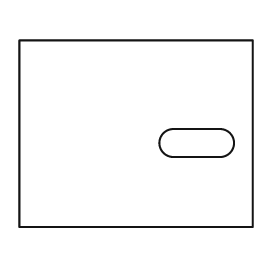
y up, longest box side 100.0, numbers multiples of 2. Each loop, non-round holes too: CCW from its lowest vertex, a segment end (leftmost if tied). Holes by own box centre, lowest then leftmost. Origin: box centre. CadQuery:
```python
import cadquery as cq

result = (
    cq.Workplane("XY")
    .moveTo(-50.0, -40.0)
    .lineTo(50.0, -40.0)
    .lineTo(50.0, 40.0)
    .lineTo(-50.0, 40.0)
    .close()
    .moveTo(16.0, -10.0)
    .lineTo(36.0, -10.0)
    .threePointArc((42.0, -4.0), (36.0, 2.0))
    .lineTo(16.0, 2.0)
    .threePointArc((10.0, -4.0), (16.0, -10.0))
    .close()
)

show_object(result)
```